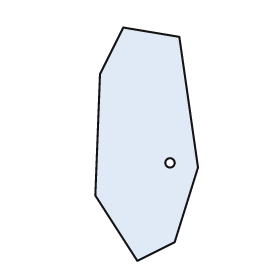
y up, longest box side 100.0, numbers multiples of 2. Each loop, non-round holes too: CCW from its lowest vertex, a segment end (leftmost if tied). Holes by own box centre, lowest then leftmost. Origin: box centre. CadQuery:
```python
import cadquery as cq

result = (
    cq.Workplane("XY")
    .moveTo(-4.0, -50.0)
    .lineTo(12.0, -42.0)
    .lineTo(22.0, -10.0)
    .lineTo(14.0, 46.0)
    .lineTo(-10.0, 50.0)
    .lineTo(-20.0, 30.0)
    .lineTo(-22.0, -22.0)
    .close()
    .moveTo(10.0, -8.0)
    .circle(2.0)
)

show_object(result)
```